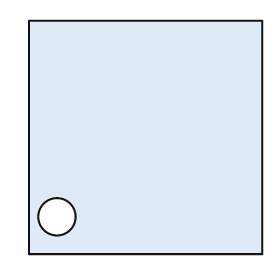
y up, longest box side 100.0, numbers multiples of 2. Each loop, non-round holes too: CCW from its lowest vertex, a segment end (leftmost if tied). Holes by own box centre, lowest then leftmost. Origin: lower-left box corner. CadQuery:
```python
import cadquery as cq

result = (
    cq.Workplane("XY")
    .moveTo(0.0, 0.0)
    .lineTo(100.0, 0.0)
    .lineTo(100.0, 100.0)
    .lineTo(0.0, 100.0)
    .close()
    .moveTo(12.0, 16.0)
    .circle(8.0)
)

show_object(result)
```